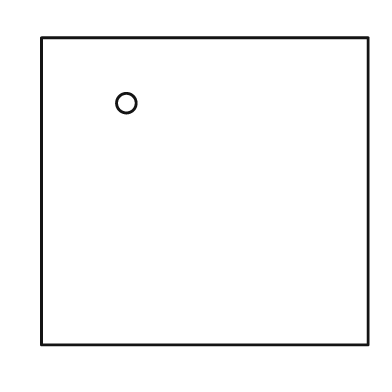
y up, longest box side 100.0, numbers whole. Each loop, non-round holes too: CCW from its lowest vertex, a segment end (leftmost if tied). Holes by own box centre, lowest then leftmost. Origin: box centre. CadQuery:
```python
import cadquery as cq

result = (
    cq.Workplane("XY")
    .moveTo(-50.0, -47.0)
    .lineTo(50.0, -47.0)
    .lineTo(50.0, 47.0)
    .lineTo(-50.0, 47.0)
    .close()
    .moveTo(-24.0, 27.0)
    .circle(3.0)
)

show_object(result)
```